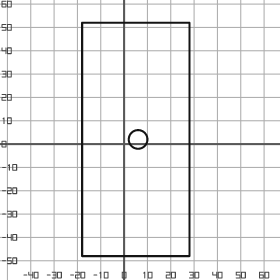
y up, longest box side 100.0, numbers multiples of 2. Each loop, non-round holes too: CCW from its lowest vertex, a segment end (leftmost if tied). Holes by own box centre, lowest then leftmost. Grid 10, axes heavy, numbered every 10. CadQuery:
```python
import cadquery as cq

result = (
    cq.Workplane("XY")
    .moveTo(-18.0, -48.0)
    .lineTo(28.0, -48.0)
    .lineTo(28.0, 52.0)
    .lineTo(-18.0, 52.0)
    .close()
    .moveTo(6.0, 2.0)
    .circle(4.0)
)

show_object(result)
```